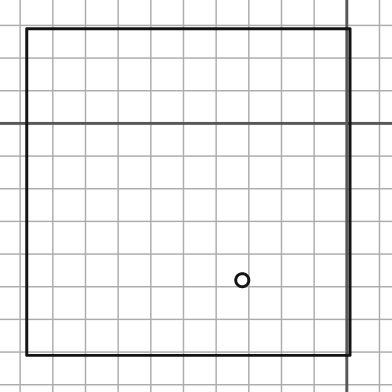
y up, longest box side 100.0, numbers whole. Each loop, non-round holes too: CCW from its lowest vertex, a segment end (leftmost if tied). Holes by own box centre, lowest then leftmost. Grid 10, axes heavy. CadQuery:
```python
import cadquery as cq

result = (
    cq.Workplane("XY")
    .moveTo(-98.0, -71.0)
    .lineTo(1.0, -71.0)
    .lineTo(1.0, 29.0)
    .lineTo(-98.0, 29.0)
    .close()
    .moveTo(-32.0, -48.0)
    .circle(2.0)
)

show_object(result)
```